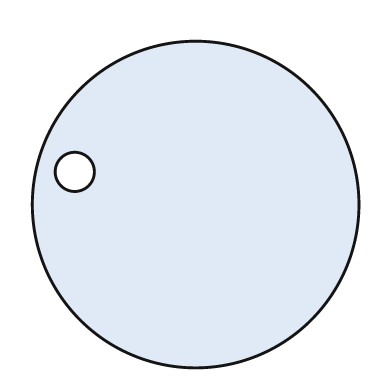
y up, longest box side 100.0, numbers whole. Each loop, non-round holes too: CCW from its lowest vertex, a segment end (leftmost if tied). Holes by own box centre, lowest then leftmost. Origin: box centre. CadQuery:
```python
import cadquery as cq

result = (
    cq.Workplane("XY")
    .moveTo(0.0, 0.0)
    .circle(50.0)
    .moveTo(-37.0, 10.0)
    .circle(6.0)
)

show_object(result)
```